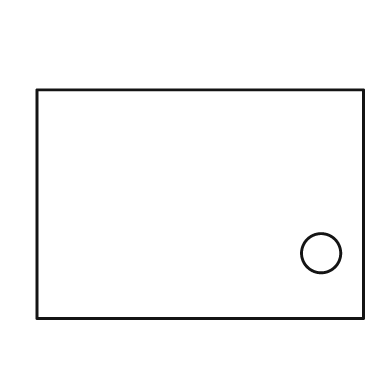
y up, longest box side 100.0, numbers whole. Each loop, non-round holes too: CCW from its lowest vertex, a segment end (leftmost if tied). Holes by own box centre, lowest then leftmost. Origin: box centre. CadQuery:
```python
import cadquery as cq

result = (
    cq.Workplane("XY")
    .moveTo(-50.0, -35.0)
    .lineTo(50.0, -35.0)
    .lineTo(50.0, 35.0)
    .lineTo(-50.0, 35.0)
    .close()
    .moveTo(37.0, -15.0)
    .circle(6.0)
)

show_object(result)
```